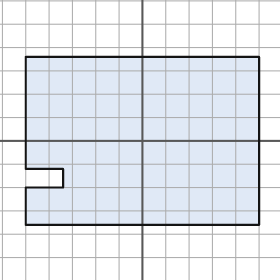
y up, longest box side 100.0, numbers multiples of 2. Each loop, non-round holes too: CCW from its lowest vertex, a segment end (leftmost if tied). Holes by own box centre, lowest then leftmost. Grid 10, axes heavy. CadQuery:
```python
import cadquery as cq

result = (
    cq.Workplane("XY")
    .moveTo(-50.0, -36.0)
    .lineTo(50.0, -36.0)
    .lineTo(50.0, 36.0)
    .lineTo(-50.0, 36.0)
    .lineTo(-50.0, -12.0)
    .lineTo(-34.0, -12.0)
    .lineTo(-34.0, -20.0)
    .lineTo(-50.0, -20.0)
    .close()
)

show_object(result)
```